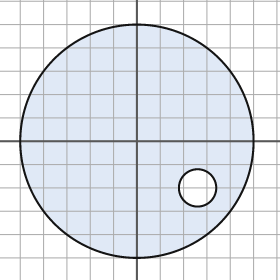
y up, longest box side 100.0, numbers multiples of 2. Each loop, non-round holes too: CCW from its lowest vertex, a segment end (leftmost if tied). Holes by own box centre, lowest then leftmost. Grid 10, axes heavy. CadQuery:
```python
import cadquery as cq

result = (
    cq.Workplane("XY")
    .moveTo(0.0, 0.0)
    .circle(50.0)
    .moveTo(26.0, -20.0)
    .circle(8.0)
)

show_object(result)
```